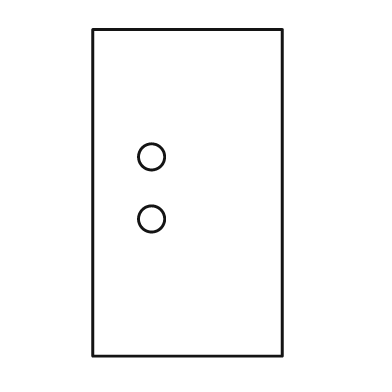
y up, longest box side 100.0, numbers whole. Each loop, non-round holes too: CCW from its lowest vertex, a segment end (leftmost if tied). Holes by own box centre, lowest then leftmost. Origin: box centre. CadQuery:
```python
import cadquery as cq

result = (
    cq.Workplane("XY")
    .moveTo(-29.0, -50.0)
    .lineTo(29.0, -50.0)
    .lineTo(29.0, 50.0)
    .lineTo(-29.0, 50.0)
    .close()
    .moveTo(-11.0, -8.0)
    .circle(4.0)
    .moveTo(-11.0, 11.0)
    .circle(4.0)
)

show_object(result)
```